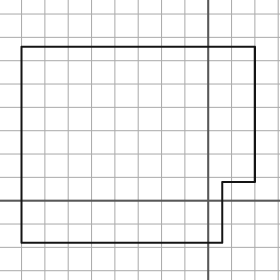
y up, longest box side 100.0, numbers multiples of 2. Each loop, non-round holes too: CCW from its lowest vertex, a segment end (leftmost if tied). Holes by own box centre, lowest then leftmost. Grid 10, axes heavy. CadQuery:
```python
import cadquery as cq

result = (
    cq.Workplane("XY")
    .moveTo(-80.0, -18.0)
    .lineTo(6.0, -18.0)
    .lineTo(6.0, 8.0)
    .lineTo(20.0, 8.0)
    .lineTo(20.0, 66.0)
    .lineTo(-80.0, 66.0)
    .close()
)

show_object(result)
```